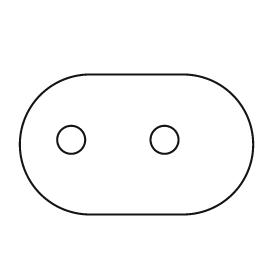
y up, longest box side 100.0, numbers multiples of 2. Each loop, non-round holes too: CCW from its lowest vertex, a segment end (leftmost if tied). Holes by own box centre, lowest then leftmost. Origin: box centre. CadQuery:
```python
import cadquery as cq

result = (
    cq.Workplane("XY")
    .moveTo(-20.0, -30.0)
    .lineTo(20.0, -30.0)
    .threePointArc((50.0, 0.0), (20.0, 30.0))
    .lineTo(-20.0, 30.0)
    .threePointArc((-50.0, 0.0), (-20.0, -30.0))
    .close()
    .moveTo(-28.0, 2.0)
    .circle(6.0)
    .moveTo(12.0, 2.0)
    .circle(6.0)
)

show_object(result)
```